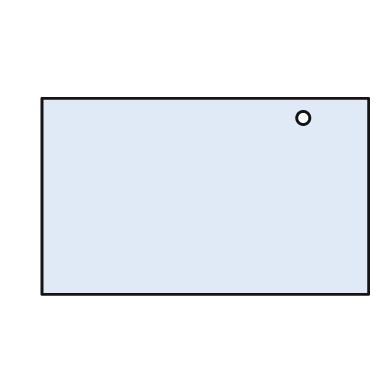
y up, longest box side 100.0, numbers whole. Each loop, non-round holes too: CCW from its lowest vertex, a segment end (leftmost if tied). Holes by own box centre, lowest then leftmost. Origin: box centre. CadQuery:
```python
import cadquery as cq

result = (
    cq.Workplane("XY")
    .moveTo(-50.0, -30.0)
    .lineTo(50.0, -30.0)
    .lineTo(50.0, 30.0)
    .lineTo(-50.0, 30.0)
    .close()
    .moveTo(30.0, 24.0)
    .circle(2.0)
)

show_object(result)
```